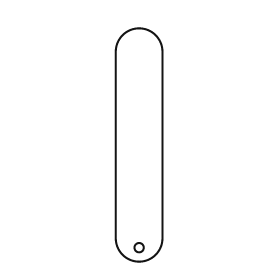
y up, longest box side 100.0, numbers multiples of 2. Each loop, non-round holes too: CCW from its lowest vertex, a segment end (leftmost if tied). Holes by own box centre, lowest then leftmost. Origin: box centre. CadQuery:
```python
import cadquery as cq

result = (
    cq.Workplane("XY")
    .moveTo(-10.0, -40.0)
    .threePointArc((0.0, -50.0), (10.0, -40.0))
    .lineTo(10.0, 40.0)
    .threePointArc((0.0, 50.0), (-10.0, 40.0))
    .close()
    .moveTo(0.0, -44.0)
    .circle(2.0)
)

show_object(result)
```